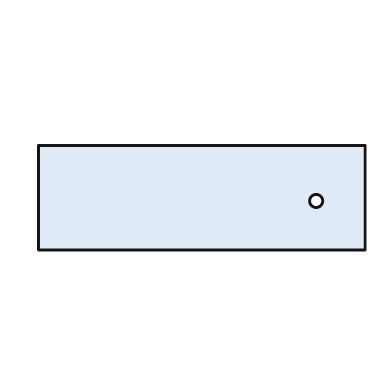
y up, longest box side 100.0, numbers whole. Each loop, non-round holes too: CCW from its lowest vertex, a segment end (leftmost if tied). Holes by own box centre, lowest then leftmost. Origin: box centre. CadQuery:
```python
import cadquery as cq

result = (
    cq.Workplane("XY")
    .moveTo(-50.0, -16.0)
    .lineTo(50.0, -16.0)
    .lineTo(50.0, 16.0)
    .lineTo(-50.0, 16.0)
    .close()
    .moveTo(35.0, -1.0)
    .circle(2.0)
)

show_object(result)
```